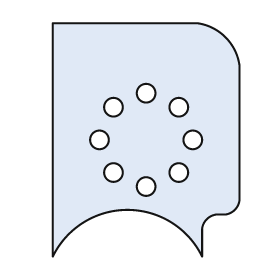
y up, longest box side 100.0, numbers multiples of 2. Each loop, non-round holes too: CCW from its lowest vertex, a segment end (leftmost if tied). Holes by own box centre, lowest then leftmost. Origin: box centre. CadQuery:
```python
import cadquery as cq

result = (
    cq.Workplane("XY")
    .moveTo(-40.0, -50.0)
    .threePointArc((-8.0, -30.0), (24.0, -50.0))
    .lineTo(24.0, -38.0)
    .threePointArc((26.0, -34.0), (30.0, -32.0))
    .lineTo(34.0, -32.0)
    .threePointArc((38.0, -30.0), (40.0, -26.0))
    .lineTo(40.0, 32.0)
    .threePointArc((34.0, 44.0), (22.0, 50.0))
    .lineTo(-40.0, 50.0)
    .close()
    .moveTo(0.0, -20.0)
    .circle(4.0)
    .moveTo(-14.0, -14.0)
    .circle(4.0)
    .moveTo(14.0, -14.0)
    .circle(4.0)
    .moveTo(-20.0, 0.0)
    .circle(4.0)
    .moveTo(20.0, 0.0)
    .circle(4.0)
    .moveTo(-14.0, 14.0)
    .circle(4.0)
    .moveTo(14.0, 14.0)
    .circle(4.0)
    .moveTo(0.0, 20.0)
    .circle(4.0)
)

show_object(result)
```